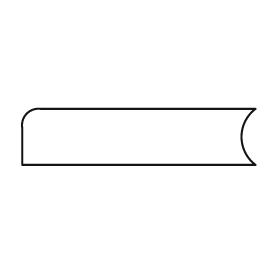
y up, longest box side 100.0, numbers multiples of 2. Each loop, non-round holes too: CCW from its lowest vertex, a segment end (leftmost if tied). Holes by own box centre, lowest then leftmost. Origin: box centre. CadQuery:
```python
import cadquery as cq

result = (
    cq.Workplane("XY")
    .moveTo(-50.0, -12.0)
    .lineTo(50.0, -12.0)
    .threePointArc((44.0, 0.0), (50.0, 12.0))
    .lineTo(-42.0, 12.0)
    .threePointArc((-48.0, 10.0), (-50.0, 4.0))
    .close()
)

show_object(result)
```